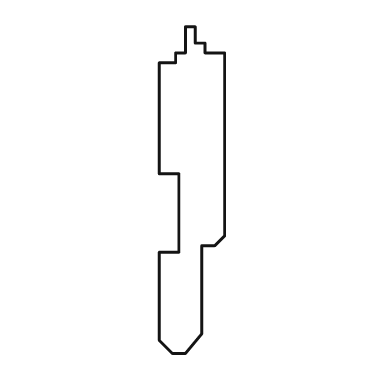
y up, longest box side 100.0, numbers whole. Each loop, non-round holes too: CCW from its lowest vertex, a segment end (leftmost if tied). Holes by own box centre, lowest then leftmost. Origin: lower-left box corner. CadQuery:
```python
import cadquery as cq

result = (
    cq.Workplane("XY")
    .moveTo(4.0, 0.0)
    .lineTo(8.0, 0.0)
    .lineTo(13.0, 6.0)
    .lineTo(13.0, 33.0)
    .lineTo(17.0, 33.0)
    .lineTo(20.0, 36.0)
    .lineTo(20.0, 92.0)
    .lineTo(14.0, 92.0)
    .lineTo(14.0, 95.0)
    .lineTo(11.0, 95.0)
    .lineTo(11.0, 100.0)
    .lineTo(8.0, 100.0)
    .lineTo(8.0, 92.0)
    .lineTo(5.0, 92.0)
    .lineTo(5.0, 89.0)
    .lineTo(0.0, 89.0)
    .lineTo(0.0, 55.0)
    .lineTo(6.0, 55.0)
    .lineTo(6.0, 31.0)
    .lineTo(0.0, 31.0)
    .lineTo(0.0, 4.0)
    .close()
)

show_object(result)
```